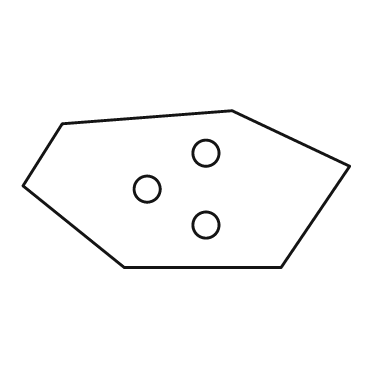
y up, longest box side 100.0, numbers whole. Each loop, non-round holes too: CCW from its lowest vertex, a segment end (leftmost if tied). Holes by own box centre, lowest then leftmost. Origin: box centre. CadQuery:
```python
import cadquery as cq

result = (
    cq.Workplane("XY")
    .moveTo(-19.0, -24.0)
    .lineTo(29.0, -24.0)
    .lineTo(50.0, 7.0)
    .lineTo(14.0, 24.0)
    .lineTo(-38.0, 20.0)
    .lineTo(-50.0, 1.0)
    .close()
    .moveTo(6.0, -11.0)
    .circle(4.0)
    .moveTo(-12.0, 0.0)
    .circle(4.0)
    .moveTo(6.0, 11.0)
    .circle(4.0)
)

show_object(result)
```